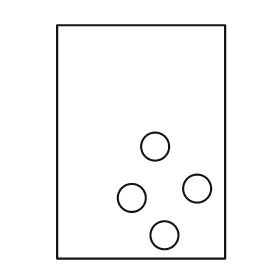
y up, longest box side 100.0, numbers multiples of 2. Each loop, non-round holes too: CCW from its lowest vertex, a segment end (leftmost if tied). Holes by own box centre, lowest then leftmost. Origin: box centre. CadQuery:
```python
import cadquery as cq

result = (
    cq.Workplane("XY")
    .moveTo(-36.0, -50.0)
    .lineTo(36.0, -50.0)
    .lineTo(36.0, 50.0)
    .lineTo(-36.0, 50.0)
    .close()
    .moveTo(10.0, -40.0)
    .circle(6.0)
    .moveTo(-4.0, -24.0)
    .circle(6.0)
    .moveTo(24.0, -20.0)
    .circle(6.0)
    .moveTo(6.0, -2.0)
    .circle(6.0)
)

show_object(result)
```